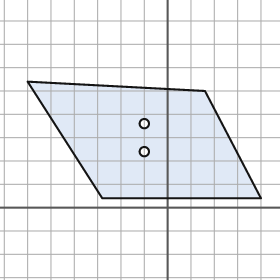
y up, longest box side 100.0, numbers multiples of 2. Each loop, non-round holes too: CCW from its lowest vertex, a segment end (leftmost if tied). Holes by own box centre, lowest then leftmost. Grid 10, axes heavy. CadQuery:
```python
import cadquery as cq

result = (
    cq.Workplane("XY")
    .moveTo(-28.0, 4.0)
    .lineTo(40.0, 4.0)
    .lineTo(16.0, 50.0)
    .lineTo(-60.0, 54.0)
    .close()
    .moveTo(-10.0, 24.0)
    .circle(2.0)
    .moveTo(-10.0, 36.0)
    .circle(2.0)
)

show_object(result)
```